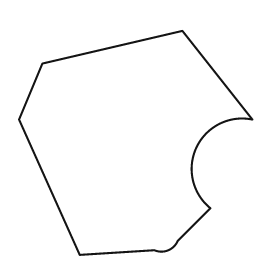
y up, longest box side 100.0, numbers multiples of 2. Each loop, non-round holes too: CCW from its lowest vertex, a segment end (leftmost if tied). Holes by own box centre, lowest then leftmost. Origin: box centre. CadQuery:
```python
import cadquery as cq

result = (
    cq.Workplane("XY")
    .moveTo(-24.0, -48.0)
    .lineTo(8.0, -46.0)
    .threePointArc((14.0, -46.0), (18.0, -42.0))
    .lineTo(32.0, -28.0)
    .threePointArc((26.0, -2.0), (50.0, 10.0))
    .lineTo(20.0, 48.0)
    .lineTo(-40.0, 34.0)
    .lineTo(-50.0, 10.0)
    .close()
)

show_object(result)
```